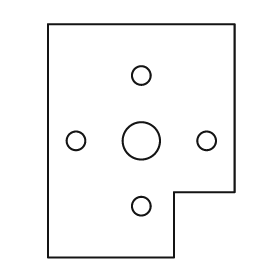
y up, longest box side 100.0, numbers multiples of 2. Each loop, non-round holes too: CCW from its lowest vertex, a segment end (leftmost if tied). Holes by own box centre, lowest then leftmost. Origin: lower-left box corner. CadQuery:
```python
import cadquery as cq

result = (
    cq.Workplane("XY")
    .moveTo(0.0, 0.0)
    .lineTo(54.0, 0.0)
    .lineTo(54.0, 28.0)
    .lineTo(80.0, 28.0)
    .lineTo(80.0, 100.0)
    .lineTo(0.0, 100.0)
    .close()
    .moveTo(40.0, 22.0)
    .circle(4.0)
    .moveTo(12.0, 50.0)
    .circle(4.0)
    .moveTo(40.0, 50.0)
    .circle(8.0)
    .moveTo(68.0, 50.0)
    .circle(4.0)
    .moveTo(40.0, 78.0)
    .circle(4.0)
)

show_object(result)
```